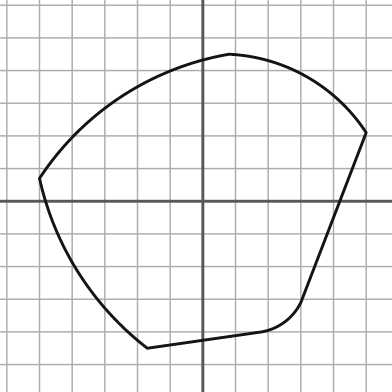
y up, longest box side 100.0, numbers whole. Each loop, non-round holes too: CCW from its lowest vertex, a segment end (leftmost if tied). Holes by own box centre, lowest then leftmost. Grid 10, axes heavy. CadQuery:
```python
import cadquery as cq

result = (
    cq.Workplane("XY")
    .moveTo(-17.0, -45.0)
    .lineTo(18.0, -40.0)
    .threePointArc((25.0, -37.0), (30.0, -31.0))
    .lineTo(50.0, 21.0)
    .threePointArc((32.0, 38.0), (8.0, 45.0))
    .threePointArc((-25.0, 32.0), (-50.0, 7.0))
    .threePointArc((-38.0, -22.0), (-17.0, -45.0))
    .close()
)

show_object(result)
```